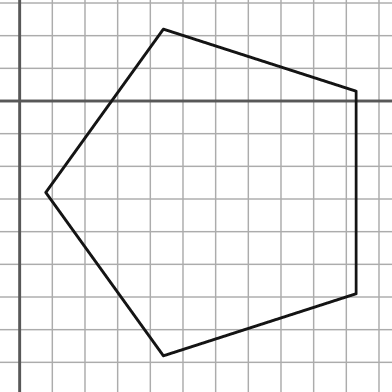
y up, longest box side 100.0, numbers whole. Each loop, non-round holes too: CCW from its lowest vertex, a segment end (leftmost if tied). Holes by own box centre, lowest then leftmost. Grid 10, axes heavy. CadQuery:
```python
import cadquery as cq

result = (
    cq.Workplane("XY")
    .moveTo(44.0, -78.0)
    .lineTo(103.0, -59.0)
    .lineTo(103.0, 3.0)
    .lineTo(44.0, 22.0)
    .lineTo(8.0, -28.0)
    .close()
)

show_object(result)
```